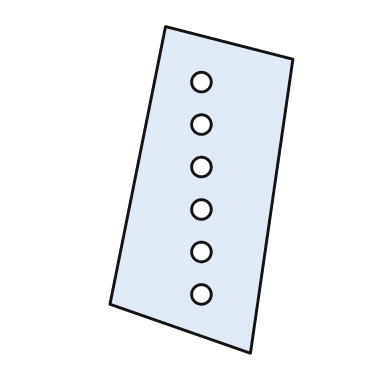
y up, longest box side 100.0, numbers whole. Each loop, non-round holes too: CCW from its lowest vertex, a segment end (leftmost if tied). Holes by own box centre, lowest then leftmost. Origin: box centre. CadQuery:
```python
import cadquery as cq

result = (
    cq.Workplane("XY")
    .moveTo(15.0, -50.0)
    .lineTo(28.0, 40.0)
    .lineTo(-11.0, 50.0)
    .lineTo(-28.0, -35.0)
    .close()
    .moveTo(0.0, -32.0)
    .circle(3.0)
    .moveTo(0.0, -19.0)
    .circle(3.0)
    .moveTo(0.0, -6.0)
    .circle(3.0)
    .moveTo(0.0, 7.0)
    .circle(3.0)
    .moveTo(0.0, 20.0)
    .circle(3.0)
    .moveTo(0.0, 33.0)
    .circle(3.0)
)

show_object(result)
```